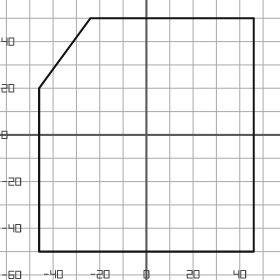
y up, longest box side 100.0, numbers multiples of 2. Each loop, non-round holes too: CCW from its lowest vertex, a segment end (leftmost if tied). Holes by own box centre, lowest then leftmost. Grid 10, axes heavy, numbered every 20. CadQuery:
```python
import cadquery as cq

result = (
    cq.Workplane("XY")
    .moveTo(-46.0, -50.0)
    .lineTo(46.0, -50.0)
    .lineTo(46.0, 50.0)
    .lineTo(-24.0, 50.0)
    .lineTo(-46.0, 20.0)
    .close()
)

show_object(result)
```